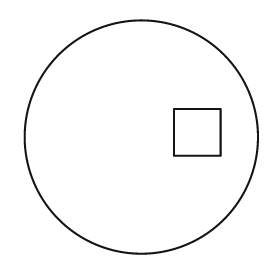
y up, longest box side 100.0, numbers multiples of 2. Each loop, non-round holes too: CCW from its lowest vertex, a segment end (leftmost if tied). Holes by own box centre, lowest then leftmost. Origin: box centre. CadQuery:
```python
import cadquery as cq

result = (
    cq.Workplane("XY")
    .moveTo(0.0, 0.0)
    .circle(50.0)
    .moveTo(14.0, -8.0)
    .lineTo(34.0, -8.0)
    .lineTo(34.0, 12.0)
    .lineTo(14.0, 12.0)
    .close()
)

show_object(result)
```